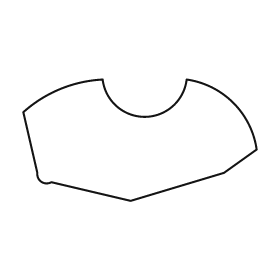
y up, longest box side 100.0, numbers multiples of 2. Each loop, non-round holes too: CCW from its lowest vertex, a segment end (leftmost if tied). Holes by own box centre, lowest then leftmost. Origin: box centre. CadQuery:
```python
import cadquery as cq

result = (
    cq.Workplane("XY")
    .moveTo(-4.0, -26.0)
    .lineTo(36.0, -14.0)
    .lineTo(50.0, -4.0)
    .threePointArc((40.0, 16.0), (20.0, 26.0))
    .threePointArc((2.0, 10.0), (-16.0, 26.0))
    .threePointArc((-34.0, 22.0), (-50.0, 12.0))
    .lineTo(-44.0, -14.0)
    .threePointArc((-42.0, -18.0), (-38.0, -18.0))
    .close()
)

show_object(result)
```